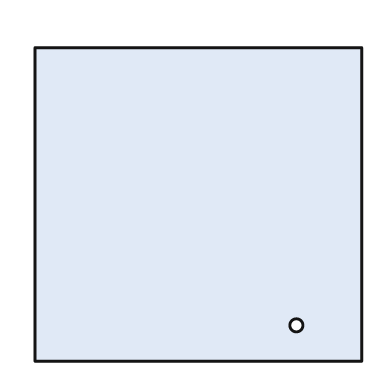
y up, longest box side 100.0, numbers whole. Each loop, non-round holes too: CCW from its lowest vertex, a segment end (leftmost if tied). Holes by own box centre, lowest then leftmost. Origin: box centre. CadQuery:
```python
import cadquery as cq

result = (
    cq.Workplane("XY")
    .moveTo(-50.0, -48.0)
    .lineTo(50.0, -48.0)
    .lineTo(50.0, 48.0)
    .lineTo(-50.0, 48.0)
    .close()
    .moveTo(30.0, -37.0)
    .circle(2.0)
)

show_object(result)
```